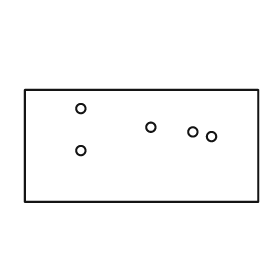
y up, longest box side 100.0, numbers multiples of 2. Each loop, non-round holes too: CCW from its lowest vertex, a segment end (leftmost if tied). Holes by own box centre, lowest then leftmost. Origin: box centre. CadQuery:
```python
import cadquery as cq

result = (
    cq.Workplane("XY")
    .moveTo(-50.0, -24.0)
    .lineTo(50.0, -24.0)
    .lineTo(50.0, 24.0)
    .lineTo(-50.0, 24.0)
    .close()
    .moveTo(-26.0, -2.0)
    .circle(2.0)
    .moveTo(30.0, 4.0)
    .circle(2.0)
    .moveTo(22.0, 6.0)
    .circle(2.0)
    .moveTo(4.0, 8.0)
    .circle(2.0)
    .moveTo(-26.0, 16.0)
    .circle(2.0)
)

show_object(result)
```